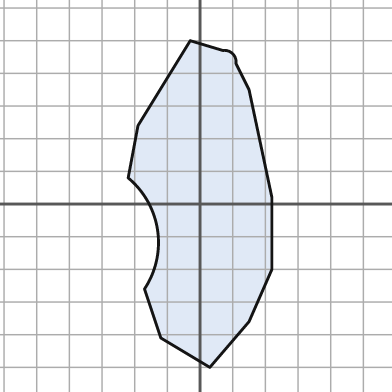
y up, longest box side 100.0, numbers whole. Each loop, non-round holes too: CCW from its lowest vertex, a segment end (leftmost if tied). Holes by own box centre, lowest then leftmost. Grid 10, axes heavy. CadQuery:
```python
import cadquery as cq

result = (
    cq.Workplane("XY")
    .moveTo(3.0, -50.0)
    .lineTo(15.0, -36.0)
    .lineTo(22.0, -20.0)
    .lineTo(22.0, 2.0)
    .lineTo(15.0, 35.0)
    .lineTo(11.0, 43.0)
    .threePointArc((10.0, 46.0), (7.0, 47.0))
    .lineTo(-3.0, 50.0)
    .lineTo(-19.0, 24.0)
    .lineTo(-22.0, 8.0)
    .threePointArc((-13.0, -8.0), (-17.0, -26.0))
    .lineTo(-12.0, -41.0)
    .close()
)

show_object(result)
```